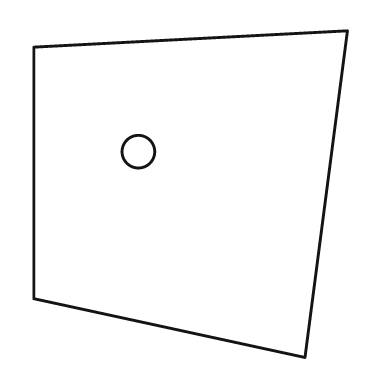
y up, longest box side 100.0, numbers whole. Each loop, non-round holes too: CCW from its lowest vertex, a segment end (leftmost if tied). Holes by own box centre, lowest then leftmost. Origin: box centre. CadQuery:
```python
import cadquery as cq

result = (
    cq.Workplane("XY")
    .moveTo(35.0, -50.0)
    .lineTo(48.0, 50.0)
    .lineTo(-48.0, 45.0)
    .lineTo(-48.0, -32.0)
    .close()
    .moveTo(-16.0, 13.0)
    .circle(5.0)
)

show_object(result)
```